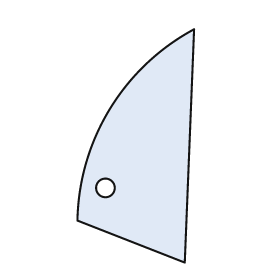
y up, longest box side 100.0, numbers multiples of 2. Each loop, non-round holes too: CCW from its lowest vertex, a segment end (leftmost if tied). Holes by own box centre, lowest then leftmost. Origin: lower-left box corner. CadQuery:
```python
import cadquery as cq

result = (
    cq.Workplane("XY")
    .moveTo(46.0, 0.0)
    .lineTo(50.0, 100.0)
    .threePointArc((14.0, 66.0), (0.0, 18.0))
    .close()
    .moveTo(12.0, 32.0)
    .circle(4.0)
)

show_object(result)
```